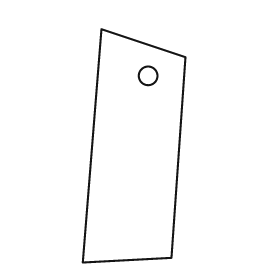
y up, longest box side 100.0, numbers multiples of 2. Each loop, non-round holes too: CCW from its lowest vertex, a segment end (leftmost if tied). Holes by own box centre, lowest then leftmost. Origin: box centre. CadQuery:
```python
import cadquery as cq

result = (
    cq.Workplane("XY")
    .moveTo(-22.0, -50.0)
    .lineTo(16.0, -48.0)
    .lineTo(22.0, 38.0)
    .lineTo(-14.0, 50.0)
    .close()
    .moveTo(6.0, 30.0)
    .circle(4.0)
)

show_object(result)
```